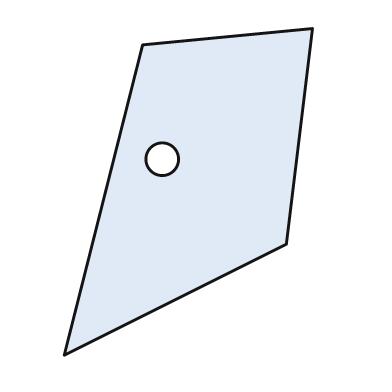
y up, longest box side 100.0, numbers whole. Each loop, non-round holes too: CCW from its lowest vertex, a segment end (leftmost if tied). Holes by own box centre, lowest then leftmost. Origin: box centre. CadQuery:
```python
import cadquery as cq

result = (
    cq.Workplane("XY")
    .moveTo(-38.0, -50.0)
    .lineTo(30.0, -16.0)
    .lineTo(38.0, 50.0)
    .lineTo(-14.0, 45.0)
    .close()
    .moveTo(-8.0, 10.0)
    .circle(5.0)
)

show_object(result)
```